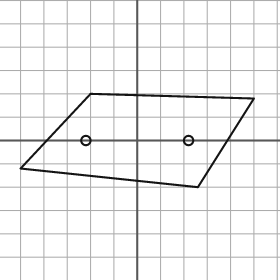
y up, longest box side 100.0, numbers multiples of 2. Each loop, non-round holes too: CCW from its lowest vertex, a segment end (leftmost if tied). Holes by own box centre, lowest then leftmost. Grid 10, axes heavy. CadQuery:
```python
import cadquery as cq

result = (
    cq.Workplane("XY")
    .moveTo(26.0, -20.0)
    .lineTo(50.0, 18.0)
    .lineTo(-20.0, 20.0)
    .lineTo(-50.0, -12.0)
    .close()
    .moveTo(-22.0, 0.0)
    .circle(2.0)
    .moveTo(22.0, 0.0)
    .circle(2.0)
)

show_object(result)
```